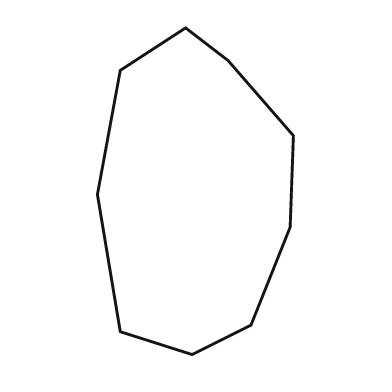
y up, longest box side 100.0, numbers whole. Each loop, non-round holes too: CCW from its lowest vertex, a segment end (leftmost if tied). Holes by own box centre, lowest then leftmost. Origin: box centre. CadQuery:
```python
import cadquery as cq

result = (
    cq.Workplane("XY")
    .moveTo(-1.0, -50.0)
    .lineTo(17.0, -41.0)
    .lineTo(29.0, -11.0)
    .lineTo(30.0, 17.0)
    .lineTo(10.0, 40.0)
    .lineTo(-3.0, 50.0)
    .lineTo(-23.0, 37.0)
    .lineTo(-30.0, -1.0)
    .lineTo(-23.0, -43.0)
    .close()
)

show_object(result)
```